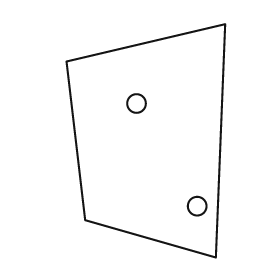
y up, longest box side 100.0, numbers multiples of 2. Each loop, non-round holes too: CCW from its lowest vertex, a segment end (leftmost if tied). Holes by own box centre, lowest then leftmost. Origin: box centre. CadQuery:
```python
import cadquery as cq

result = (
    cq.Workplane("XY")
    .moveTo(30.0, -50.0)
    .lineTo(34.0, 50.0)
    .lineTo(-34.0, 34.0)
    .lineTo(-26.0, -34.0)
    .close()
    .moveTo(22.0, -28.0)
    .circle(4.0)
    .moveTo(-4.0, 16.0)
    .circle(4.0)
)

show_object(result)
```